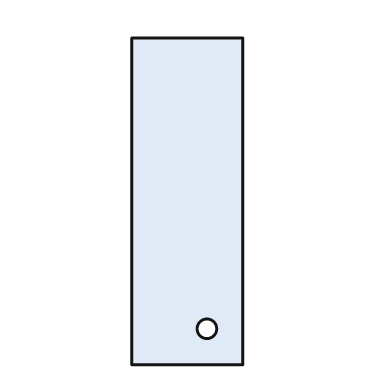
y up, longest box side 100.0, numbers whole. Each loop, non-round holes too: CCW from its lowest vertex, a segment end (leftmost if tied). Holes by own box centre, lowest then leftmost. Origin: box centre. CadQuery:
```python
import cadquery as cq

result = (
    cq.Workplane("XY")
    .moveTo(-17.0, -50.0)
    .lineTo(17.0, -50.0)
    .lineTo(17.0, 50.0)
    .lineTo(-17.0, 50.0)
    .close()
    .moveTo(6.0, -39.0)
    .circle(3.0)
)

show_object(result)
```